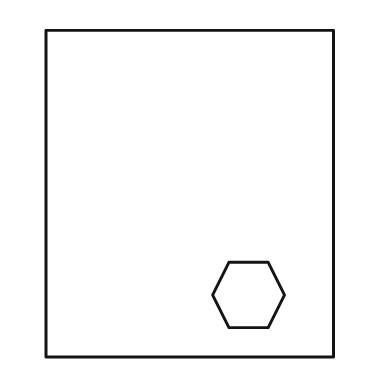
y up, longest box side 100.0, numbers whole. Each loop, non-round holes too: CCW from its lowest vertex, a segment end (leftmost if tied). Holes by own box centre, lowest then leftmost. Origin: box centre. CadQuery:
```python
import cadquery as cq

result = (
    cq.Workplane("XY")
    .moveTo(-44.0, -50.0)
    .lineTo(44.0, -50.0)
    .lineTo(44.0, 50.0)
    .lineTo(-44.0, 50.0)
    .close()
    .moveTo(12.0, -41.0)
    .lineTo(24.0, -41.0)
    .lineTo(29.0, -31.0)
    .lineTo(24.0, -21.0)
    .lineTo(12.0, -21.0)
    .lineTo(7.0, -31.0)
    .close()
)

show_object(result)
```